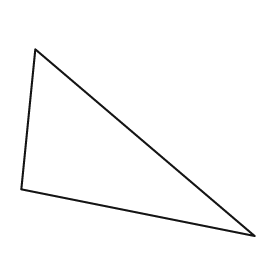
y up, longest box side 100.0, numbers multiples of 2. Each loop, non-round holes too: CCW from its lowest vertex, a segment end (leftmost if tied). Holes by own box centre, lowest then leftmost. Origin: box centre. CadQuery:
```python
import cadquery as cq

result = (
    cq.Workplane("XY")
    .moveTo(50.0, -40.0)
    .lineTo(-44.0, 40.0)
    .lineTo(-50.0, -20.0)
    .close()
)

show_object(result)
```